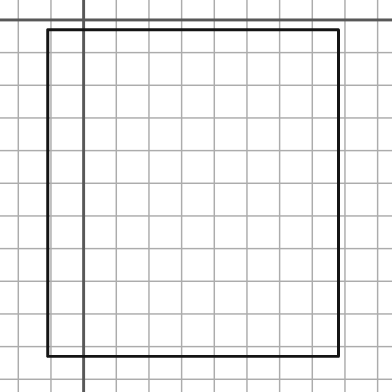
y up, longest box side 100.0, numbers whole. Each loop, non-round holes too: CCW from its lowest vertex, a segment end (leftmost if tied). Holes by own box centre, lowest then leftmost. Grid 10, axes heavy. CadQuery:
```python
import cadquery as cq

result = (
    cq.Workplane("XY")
    .moveTo(-11.0, -103.0)
    .lineTo(78.0, -103.0)
    .lineTo(78.0, -3.0)
    .lineTo(-11.0, -3.0)
    .close()
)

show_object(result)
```